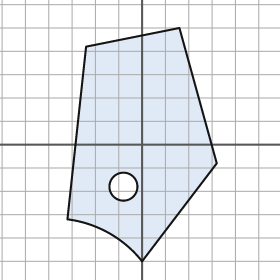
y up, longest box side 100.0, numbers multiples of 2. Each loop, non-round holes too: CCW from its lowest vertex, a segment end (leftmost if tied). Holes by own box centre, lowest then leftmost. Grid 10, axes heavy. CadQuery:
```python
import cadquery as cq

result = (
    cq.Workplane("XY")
    .moveTo(0.0, -50.0)
    .lineTo(32.0, -8.0)
    .lineTo(16.0, 50.0)
    .lineTo(-24.0, 42.0)
    .lineTo(-32.0, -32.0)
    .threePointArc((-14.0, -38.0), (0.0, -50.0))
    .close()
    .moveTo(-8.0, -18.0)
    .circle(6.0)
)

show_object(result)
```